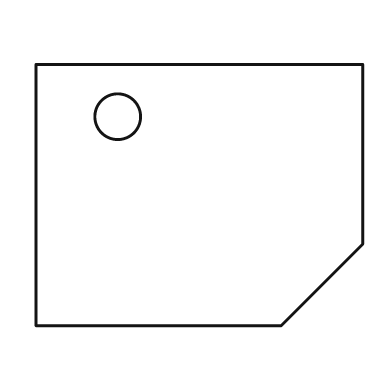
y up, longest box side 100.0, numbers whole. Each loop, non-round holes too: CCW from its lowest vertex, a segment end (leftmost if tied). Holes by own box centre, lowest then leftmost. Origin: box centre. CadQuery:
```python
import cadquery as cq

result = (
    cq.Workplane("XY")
    .moveTo(-50.0, -40.0)
    .lineTo(25.0, -40.0)
    .lineTo(50.0, -15.0)
    .lineTo(50.0, 40.0)
    .lineTo(-50.0, 40.0)
    .close()
    .moveTo(-25.0, 24.0)
    .circle(7.0)
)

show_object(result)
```